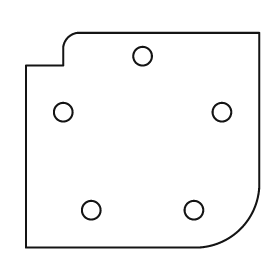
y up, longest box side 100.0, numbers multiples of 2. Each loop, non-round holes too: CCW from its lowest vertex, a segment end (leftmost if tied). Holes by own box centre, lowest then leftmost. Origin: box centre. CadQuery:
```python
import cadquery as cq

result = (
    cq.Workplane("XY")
    .moveTo(-50.0, -46.0)
    .lineTo(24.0, -46.0)
    .threePointArc((42.0, -38.0), (50.0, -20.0))
    .lineTo(50.0, 46.0)
    .lineTo(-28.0, 46.0)
    .threePointArc((-32.0, 44.0), (-34.0, 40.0))
    .lineTo(-34.0, 32.0)
    .lineTo(-50.0, 32.0)
    .close()
    .moveTo(-22.0, -30.0)
    .circle(4.0)
    .moveTo(22.0, -30.0)
    .circle(4.0)
    .moveTo(-34.0, 12.0)
    .circle(4.0)
    .moveTo(34.0, 12.0)
    .circle(4.0)
    .moveTo(0.0, 36.0)
    .circle(4.0)
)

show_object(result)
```